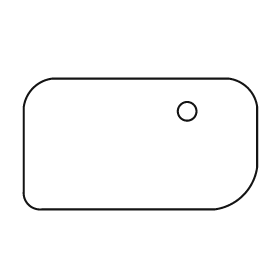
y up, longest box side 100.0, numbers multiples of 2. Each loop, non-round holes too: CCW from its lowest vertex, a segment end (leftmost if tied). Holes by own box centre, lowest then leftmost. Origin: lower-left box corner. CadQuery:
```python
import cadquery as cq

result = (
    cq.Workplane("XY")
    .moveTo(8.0, 0.0)
    .lineTo(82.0, 0.0)
    .threePointArc((94.0, 6.0), (100.0, 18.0))
    .lineTo(100.0, 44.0)
    .threePointArc((96.0, 52.0), (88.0, 56.0))
    .lineTo(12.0, 56.0)
    .threePointArc((4.0, 52.0), (0.0, 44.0))
    .lineTo(0.0, 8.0)
    .threePointArc((2.0, 2.0), (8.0, 0.0))
    .close()
    .moveTo(70.0, 42.0)
    .circle(4.0)
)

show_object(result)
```